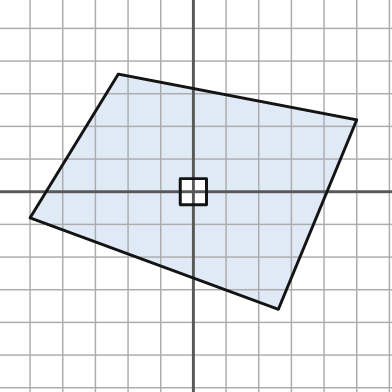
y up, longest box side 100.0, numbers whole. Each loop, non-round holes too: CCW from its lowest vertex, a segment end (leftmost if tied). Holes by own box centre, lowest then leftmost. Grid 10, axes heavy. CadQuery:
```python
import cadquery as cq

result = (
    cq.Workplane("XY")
    .moveTo(26.0, -36.0)
    .lineTo(50.0, 22.0)
    .lineTo(-23.0, 36.0)
    .lineTo(-50.0, -8.0)
    .close()
    .moveTo(-4.0, -4.0)
    .lineTo(4.0, -4.0)
    .lineTo(4.0, 4.0)
    .lineTo(-4.0, 4.0)
    .close()
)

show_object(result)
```